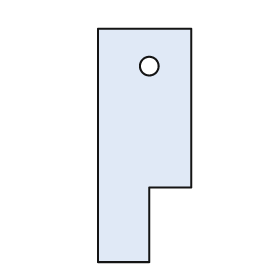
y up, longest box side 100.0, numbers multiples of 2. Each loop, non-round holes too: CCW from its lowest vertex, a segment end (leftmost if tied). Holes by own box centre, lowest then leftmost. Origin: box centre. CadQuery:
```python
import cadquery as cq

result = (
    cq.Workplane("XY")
    .moveTo(-20.0, -50.0)
    .lineTo(2.0, -50.0)
    .lineTo(2.0, -18.0)
    .lineTo(20.0, -18.0)
    .lineTo(20.0, 50.0)
    .lineTo(-20.0, 50.0)
    .close()
    .moveTo(2.0, 34.0)
    .circle(4.0)
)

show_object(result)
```